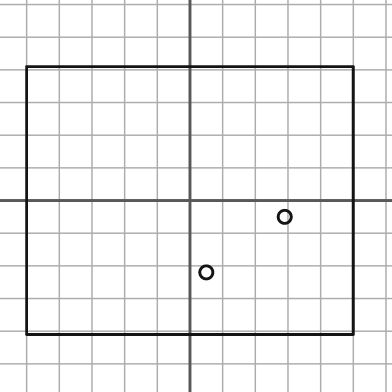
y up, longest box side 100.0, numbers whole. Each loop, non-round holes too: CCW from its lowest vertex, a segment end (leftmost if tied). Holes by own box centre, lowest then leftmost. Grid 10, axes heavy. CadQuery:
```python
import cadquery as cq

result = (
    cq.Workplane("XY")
    .moveTo(-50.0, -41.0)
    .lineTo(50.0, -41.0)
    .lineTo(50.0, 41.0)
    .lineTo(-50.0, 41.0)
    .close()
    .moveTo(5.0, -22.0)
    .circle(2.0)
    .moveTo(29.0, -5.0)
    .circle(2.0)
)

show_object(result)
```